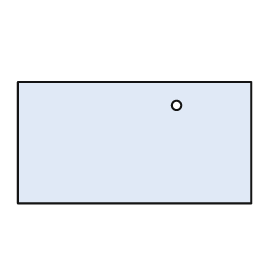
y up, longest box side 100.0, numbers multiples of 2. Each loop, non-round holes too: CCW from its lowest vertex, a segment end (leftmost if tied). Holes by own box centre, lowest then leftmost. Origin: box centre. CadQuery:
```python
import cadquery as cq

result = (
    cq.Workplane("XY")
    .moveTo(-50.0, -26.0)
    .lineTo(50.0, -26.0)
    .lineTo(50.0, 26.0)
    .lineTo(-50.0, 26.0)
    .close()
    .moveTo(18.0, 16.0)
    .circle(2.0)
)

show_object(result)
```